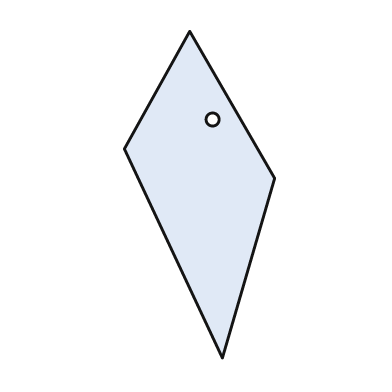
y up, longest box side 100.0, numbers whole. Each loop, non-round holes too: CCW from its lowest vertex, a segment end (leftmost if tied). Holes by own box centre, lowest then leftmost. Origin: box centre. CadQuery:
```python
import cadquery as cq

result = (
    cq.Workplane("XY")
    .moveTo(7.0, -50.0)
    .lineTo(23.0, 5.0)
    .lineTo(-3.0, 50.0)
    .lineTo(-23.0, 14.0)
    .close()
    .moveTo(4.0, 23.0)
    .circle(2.0)
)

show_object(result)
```